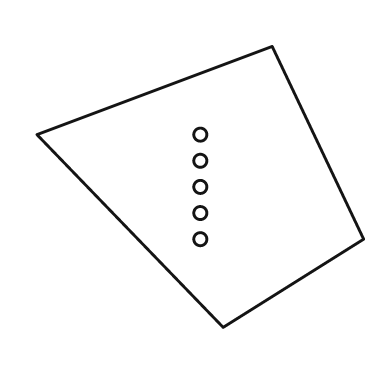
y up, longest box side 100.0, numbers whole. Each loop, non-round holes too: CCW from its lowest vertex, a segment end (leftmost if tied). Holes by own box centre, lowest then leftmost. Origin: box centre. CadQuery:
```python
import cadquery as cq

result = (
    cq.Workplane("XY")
    .moveTo(7.0, -43.0)
    .lineTo(50.0, -16.0)
    .lineTo(22.0, 43.0)
    .lineTo(-50.0, 16.0)
    .close()
    .moveTo(0.0, -16.0)
    .circle(2.0)
    .moveTo(0.0, -8.0)
    .circle(2.0)
    .moveTo(0.0, 0.0)
    .circle(2.0)
    .moveTo(0.0, 8.0)
    .circle(2.0)
    .moveTo(0.0, 16.0)
    .circle(2.0)
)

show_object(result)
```